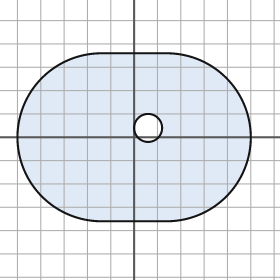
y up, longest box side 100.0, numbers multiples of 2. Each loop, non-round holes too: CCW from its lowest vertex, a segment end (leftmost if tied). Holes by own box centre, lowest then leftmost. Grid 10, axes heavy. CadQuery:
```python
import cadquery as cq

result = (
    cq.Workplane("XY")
    .moveTo(-14.0, -36.0)
    .lineTo(14.0, -36.0)
    .threePointArc((50.0, 0.0), (14.0, 36.0))
    .lineTo(-14.0, 36.0)
    .threePointArc((-50.0, 0.0), (-14.0, -36.0))
    .close()
    .moveTo(6.0, 4.0)
    .circle(6.0)
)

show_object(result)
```